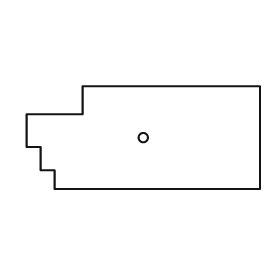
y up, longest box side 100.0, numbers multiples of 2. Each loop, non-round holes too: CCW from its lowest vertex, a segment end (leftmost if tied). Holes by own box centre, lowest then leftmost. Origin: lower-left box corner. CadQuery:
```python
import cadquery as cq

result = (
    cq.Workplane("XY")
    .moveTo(12.0, 0.0)
    .lineTo(100.0, 0.0)
    .lineTo(100.0, 44.0)
    .lineTo(24.0, 44.0)
    .lineTo(24.0, 32.0)
    .lineTo(0.0, 32.0)
    .lineTo(0.0, 18.0)
    .lineTo(6.0, 18.0)
    .lineTo(6.0, 8.0)
    .lineTo(12.0, 8.0)
    .close()
    .moveTo(50.0, 22.0)
    .circle(2.0)
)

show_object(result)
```